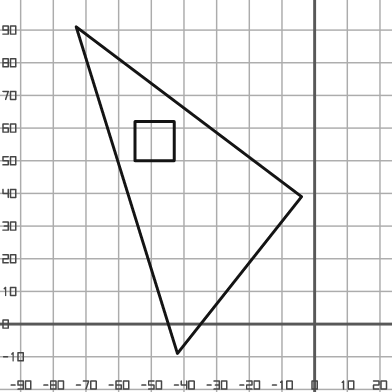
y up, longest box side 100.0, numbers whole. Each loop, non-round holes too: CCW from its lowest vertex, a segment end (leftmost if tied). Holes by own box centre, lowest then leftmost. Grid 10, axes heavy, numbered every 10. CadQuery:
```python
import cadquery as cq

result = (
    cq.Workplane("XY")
    .moveTo(-42.0, -9.0)
    .lineTo(-4.0, 39.0)
    .lineTo(-73.0, 91.0)
    .close()
    .moveTo(-55.0, 50.0)
    .lineTo(-43.0, 50.0)
    .lineTo(-43.0, 62.0)
    .lineTo(-55.0, 62.0)
    .close()
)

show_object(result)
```